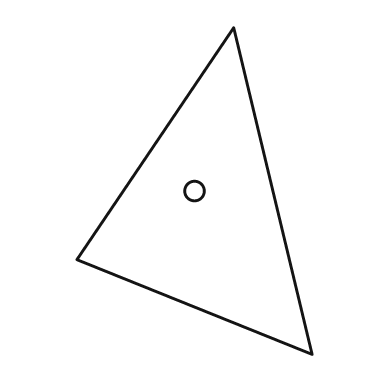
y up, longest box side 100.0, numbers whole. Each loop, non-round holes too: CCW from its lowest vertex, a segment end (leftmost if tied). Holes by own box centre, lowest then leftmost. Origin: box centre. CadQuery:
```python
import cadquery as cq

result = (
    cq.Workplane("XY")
    .moveTo(36.0, -50.0)
    .lineTo(12.0, 50.0)
    .lineTo(-36.0, -21.0)
    .close()
    .moveTo(0.0, 0.0)
    .circle(3.0)
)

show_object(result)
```